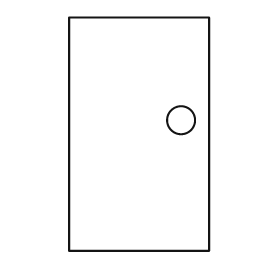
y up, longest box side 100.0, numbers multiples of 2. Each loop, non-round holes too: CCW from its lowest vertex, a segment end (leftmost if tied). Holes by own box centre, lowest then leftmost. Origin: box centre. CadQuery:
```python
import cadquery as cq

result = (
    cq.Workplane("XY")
    .moveTo(-30.0, -50.0)
    .lineTo(30.0, -50.0)
    .lineTo(30.0, 50.0)
    .lineTo(-30.0, 50.0)
    .close()
    .moveTo(18.0, 6.0)
    .circle(6.0)
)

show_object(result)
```